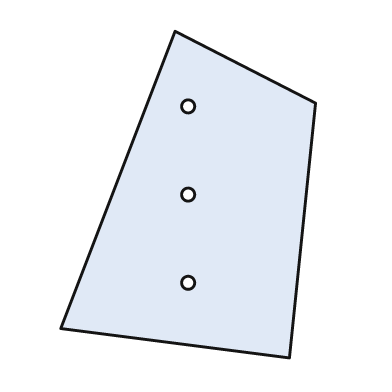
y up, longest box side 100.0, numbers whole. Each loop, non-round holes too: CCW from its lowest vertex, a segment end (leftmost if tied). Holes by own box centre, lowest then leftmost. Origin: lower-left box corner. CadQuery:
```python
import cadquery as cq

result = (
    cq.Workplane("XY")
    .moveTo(70.0, 0.0)
    .lineTo(78.0, 78.0)
    .lineTo(35.0, 100.0)
    .lineTo(0.0, 9.0)
    .close()
    .moveTo(39.0, 23.0)
    .circle(2.0)
    .moveTo(39.0, 50.0)
    .circle(2.0)
    .moveTo(39.0, 77.0)
    .circle(2.0)
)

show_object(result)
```